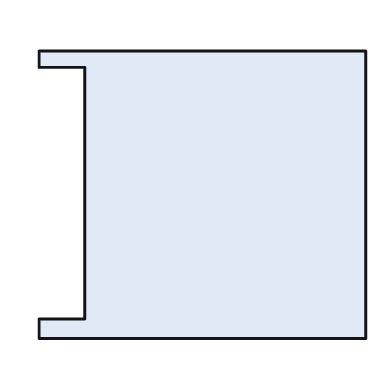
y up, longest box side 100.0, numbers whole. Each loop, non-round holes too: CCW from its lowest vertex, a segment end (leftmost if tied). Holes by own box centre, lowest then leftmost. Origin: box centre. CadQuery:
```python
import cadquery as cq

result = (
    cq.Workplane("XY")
    .moveTo(-50.0, -44.0)
    .lineTo(50.0, -44.0)
    .lineTo(50.0, 44.0)
    .lineTo(-50.0, 44.0)
    .lineTo(-50.0, 39.0)
    .lineTo(-36.0, 39.0)
    .lineTo(-36.0, -38.0)
    .lineTo(-50.0, -38.0)
    .close()
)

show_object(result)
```